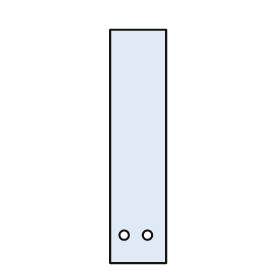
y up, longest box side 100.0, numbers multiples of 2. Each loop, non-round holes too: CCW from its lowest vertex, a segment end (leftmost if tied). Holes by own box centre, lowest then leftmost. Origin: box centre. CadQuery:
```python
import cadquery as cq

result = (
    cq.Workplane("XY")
    .moveTo(-12.0, -50.0)
    .lineTo(12.0, -50.0)
    .lineTo(12.0, 50.0)
    .lineTo(-12.0, 50.0)
    .close()
    .moveTo(-6.0, -38.0)
    .circle(2.0)
    .moveTo(4.0, -38.0)
    .circle(2.0)
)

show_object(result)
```